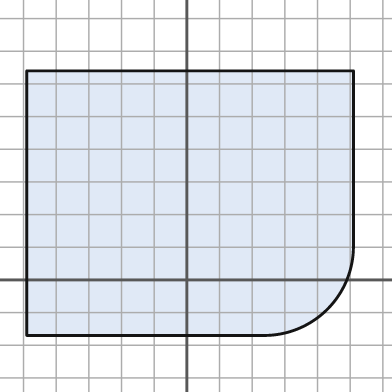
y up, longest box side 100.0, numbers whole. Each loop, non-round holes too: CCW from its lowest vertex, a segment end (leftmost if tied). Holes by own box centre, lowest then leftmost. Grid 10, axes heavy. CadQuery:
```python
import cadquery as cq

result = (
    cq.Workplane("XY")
    .moveTo(-49.0, -17.0)
    .lineTo(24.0, -17.0)
    .threePointArc((43.0, -9.0), (51.0, 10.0))
    .lineTo(51.0, 64.0)
    .lineTo(-49.0, 64.0)
    .close()
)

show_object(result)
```